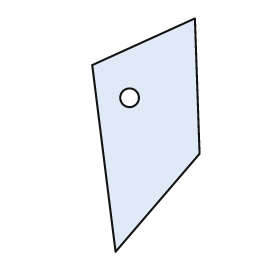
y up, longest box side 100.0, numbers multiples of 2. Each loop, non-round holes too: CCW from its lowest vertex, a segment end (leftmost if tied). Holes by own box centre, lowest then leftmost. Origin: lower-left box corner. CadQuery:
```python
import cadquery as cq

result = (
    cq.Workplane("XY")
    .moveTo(10.0, 0.0)
    .lineTo(46.0, 42.0)
    .lineTo(44.0, 100.0)
    .lineTo(0.0, 80.0)
    .close()
    .moveTo(16.0, 66.0)
    .circle(4.0)
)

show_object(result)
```